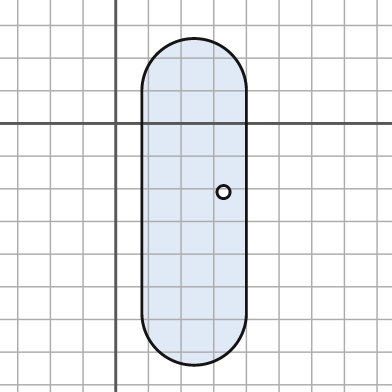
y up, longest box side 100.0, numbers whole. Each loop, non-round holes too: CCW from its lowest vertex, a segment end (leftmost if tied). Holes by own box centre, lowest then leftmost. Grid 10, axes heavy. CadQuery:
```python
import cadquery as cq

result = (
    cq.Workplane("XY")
    .moveTo(8.0, -58.0)
    .threePointArc((24.0, -74.0), (40.0, -58.0))
    .lineTo(40.0, 10.0)
    .threePointArc((24.0, 26.0), (8.0, 10.0))
    .close()
    .moveTo(33.0, -21.0)
    .circle(2.0)
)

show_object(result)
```